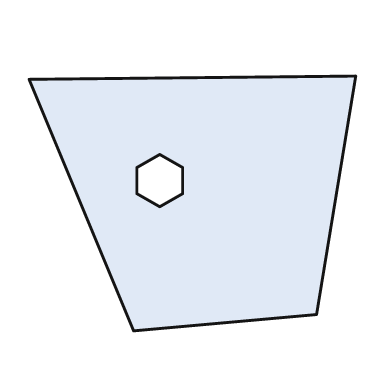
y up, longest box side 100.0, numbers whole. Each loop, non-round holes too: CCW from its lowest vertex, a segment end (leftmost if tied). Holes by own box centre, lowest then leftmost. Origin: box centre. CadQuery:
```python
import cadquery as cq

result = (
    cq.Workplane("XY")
    .moveTo(-18.0, -39.0)
    .lineTo(38.0, -34.0)
    .lineTo(50.0, 39.0)
    .lineTo(-50.0, 38.0)
    .close()
    .moveTo(-10.0, -1.0)
    .lineTo(-3.0, 3.0)
    .lineTo(-3.0, 11.0)
    .lineTo(-10.0, 15.0)
    .lineTo(-17.0, 11.0)
    .lineTo(-17.0, 3.0)
    .close()
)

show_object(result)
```